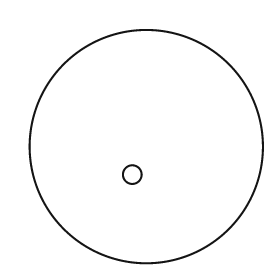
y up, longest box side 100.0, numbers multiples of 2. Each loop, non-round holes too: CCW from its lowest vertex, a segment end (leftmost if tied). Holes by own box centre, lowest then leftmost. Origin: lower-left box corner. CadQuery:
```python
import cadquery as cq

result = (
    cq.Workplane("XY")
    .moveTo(50.0, 50.0)
    .circle(50.0)
    .moveTo(44.0, 38.0)
    .circle(4.0)
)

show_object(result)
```